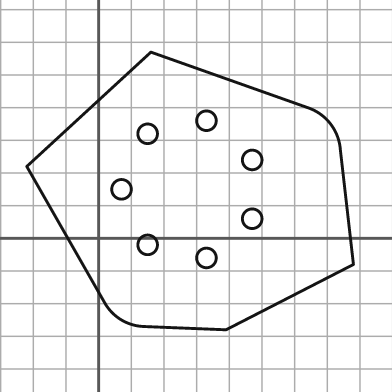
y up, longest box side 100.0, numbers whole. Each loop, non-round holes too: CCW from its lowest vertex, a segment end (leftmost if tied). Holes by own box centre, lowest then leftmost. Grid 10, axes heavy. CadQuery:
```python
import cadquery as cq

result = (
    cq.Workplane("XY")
    .moveTo(39.0, -28.0)
    .lineTo(78.0, -8.0)
    .lineTo(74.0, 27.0)
    .threePointArc((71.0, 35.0), (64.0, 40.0))
    .lineTo(16.0, 57.0)
    .lineTo(-22.0, 22.0)
    .lineTo(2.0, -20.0)
    .threePointArc((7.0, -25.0), (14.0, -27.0))
    .close()
    .moveTo(33.0, -6.0)
    .circle(3.0)
    .moveTo(15.0, -2.0)
    .circle(3.0)
    .moveTo(47.0, 6.0)
    .circle(3.0)
    .moveTo(7.0, 15.0)
    .circle(3.0)
    .moveTo(47.0, 24.0)
    .circle(3.0)
    .moveTo(15.0, 32.0)
    .circle(3.0)
    .moveTo(33.0, 36.0)
    .circle(3.0)
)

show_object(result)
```